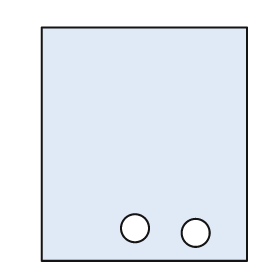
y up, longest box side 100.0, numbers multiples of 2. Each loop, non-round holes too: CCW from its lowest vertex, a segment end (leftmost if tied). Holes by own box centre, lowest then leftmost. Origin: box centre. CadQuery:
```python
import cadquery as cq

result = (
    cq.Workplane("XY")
    .moveTo(-44.0, -50.0)
    .lineTo(44.0, -50.0)
    .lineTo(44.0, 50.0)
    .lineTo(-44.0, 50.0)
    .close()
    .moveTo(22.0, -38.0)
    .circle(6.0)
    .moveTo(-4.0, -36.0)
    .circle(6.0)
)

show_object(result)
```